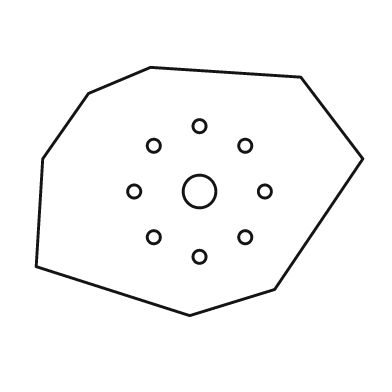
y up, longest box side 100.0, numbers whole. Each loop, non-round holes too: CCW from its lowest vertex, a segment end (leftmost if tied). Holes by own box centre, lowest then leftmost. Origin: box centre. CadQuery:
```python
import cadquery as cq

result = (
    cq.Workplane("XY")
    .moveTo(-3.0, -38.0)
    .lineTo(23.0, -30.0)
    .lineTo(50.0, 10.0)
    .lineTo(31.0, 35.0)
    .lineTo(-15.0, 38.0)
    .lineTo(-34.0, 30.0)
    .lineTo(-48.0, 10.0)
    .lineTo(-50.0, -23.0)
    .close()
    .moveTo(0.0, -20.0)
    .circle(2.0)
    .moveTo(-14.0, -14.0)
    .circle(2.0)
    .moveTo(14.0, -14.0)
    .circle(2.0)
    .moveTo(-20.0, 0.0)
    .circle(2.0)
    .moveTo(0.0, 0.0)
    .circle(5.0)
    .moveTo(20.0, 0.0)
    .circle(2.0)
    .moveTo(-14.0, 14.0)
    .circle(2.0)
    .moveTo(14.0, 14.0)
    .circle(2.0)
    .moveTo(0.0, 20.0)
    .circle(2.0)
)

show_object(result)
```